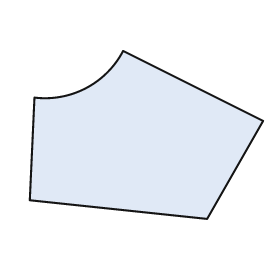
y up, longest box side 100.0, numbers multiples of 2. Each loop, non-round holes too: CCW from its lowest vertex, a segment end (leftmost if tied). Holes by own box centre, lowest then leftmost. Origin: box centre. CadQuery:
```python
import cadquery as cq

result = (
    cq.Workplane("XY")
    .moveTo(26.0, -36.0)
    .lineTo(50.0, 6.0)
    .lineTo(-10.0, 36.0)
    .threePointArc((-26.0, 20.0), (-48.0, 16.0))
    .lineTo(-50.0, -28.0)
    .close()
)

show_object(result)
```